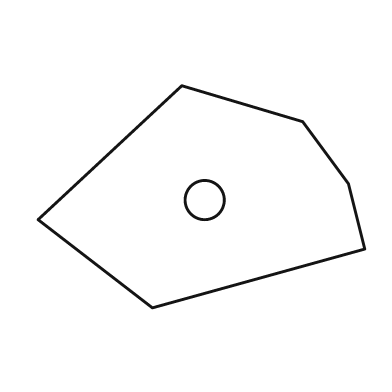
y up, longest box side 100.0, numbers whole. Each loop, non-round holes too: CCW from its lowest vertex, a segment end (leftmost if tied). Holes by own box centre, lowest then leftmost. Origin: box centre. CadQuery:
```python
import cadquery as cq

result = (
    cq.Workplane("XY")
    .moveTo(-15.0, -34.0)
    .lineTo(50.0, -16.0)
    .lineTo(45.0, 4.0)
    .lineTo(31.0, 23.0)
    .lineTo(-6.0, 34.0)
    .lineTo(-50.0, -7.0)
    .close()
    .moveTo(1.0, -1.0)
    .circle(6.0)
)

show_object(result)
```